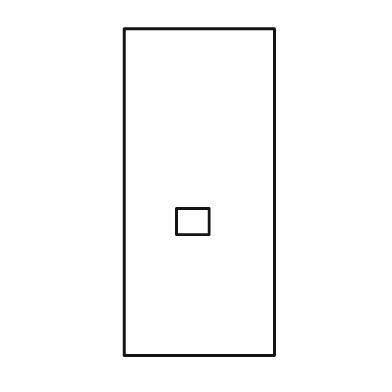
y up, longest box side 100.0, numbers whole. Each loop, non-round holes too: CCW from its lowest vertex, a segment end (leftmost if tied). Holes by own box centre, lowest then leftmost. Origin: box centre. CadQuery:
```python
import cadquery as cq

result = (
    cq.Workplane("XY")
    .moveTo(-23.0, -50.0)
    .lineTo(23.0, -50.0)
    .lineTo(23.0, 50.0)
    .lineTo(-23.0, 50.0)
    .close()
    .moveTo(-7.0, -13.0)
    .lineTo(3.0, -13.0)
    .lineTo(3.0, -5.0)
    .lineTo(-7.0, -5.0)
    .close()
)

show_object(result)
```